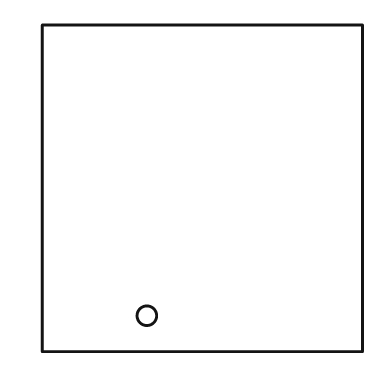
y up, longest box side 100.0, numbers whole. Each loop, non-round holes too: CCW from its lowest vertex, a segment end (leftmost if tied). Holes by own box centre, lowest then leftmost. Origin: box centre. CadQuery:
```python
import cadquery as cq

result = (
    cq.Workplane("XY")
    .moveTo(-49.0, -50.0)
    .lineTo(49.0, -50.0)
    .lineTo(49.0, 50.0)
    .lineTo(-49.0, 50.0)
    .close()
    .moveTo(-17.0, -39.0)
    .circle(3.0)
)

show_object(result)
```